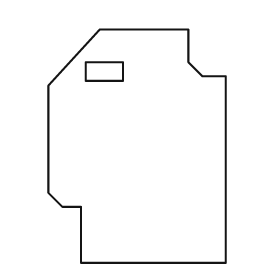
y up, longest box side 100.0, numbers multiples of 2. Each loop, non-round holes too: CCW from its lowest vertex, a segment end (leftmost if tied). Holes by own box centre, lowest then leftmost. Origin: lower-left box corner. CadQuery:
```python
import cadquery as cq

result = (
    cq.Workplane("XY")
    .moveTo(14.0, 0.0)
    .lineTo(76.0, 0.0)
    .lineTo(76.0, 80.0)
    .lineTo(66.0, 80.0)
    .lineTo(60.0, 86.0)
    .lineTo(60.0, 100.0)
    .lineTo(22.0, 100.0)
    .lineTo(0.0, 76.0)
    .lineTo(0.0, 30.0)
    .lineTo(6.0, 24.0)
    .lineTo(14.0, 24.0)
    .close()
    .moveTo(16.0, 78.0)
    .lineTo(32.0, 78.0)
    .lineTo(32.0, 86.0)
    .lineTo(16.0, 86.0)
    .close()
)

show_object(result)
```